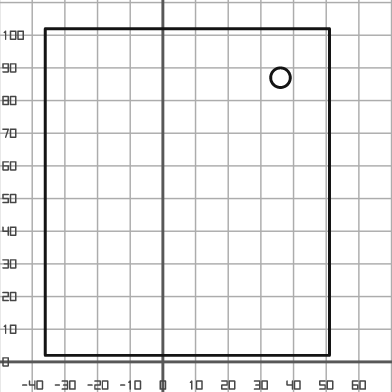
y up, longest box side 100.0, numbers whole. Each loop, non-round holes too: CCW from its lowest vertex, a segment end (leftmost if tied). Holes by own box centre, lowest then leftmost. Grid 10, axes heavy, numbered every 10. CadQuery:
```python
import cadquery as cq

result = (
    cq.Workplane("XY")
    .moveTo(-36.0, 2.0)
    .lineTo(51.0, 2.0)
    .lineTo(51.0, 102.0)
    .lineTo(-36.0, 102.0)
    .close()
    .moveTo(36.0, 87.0)
    .circle(3.0)
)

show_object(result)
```